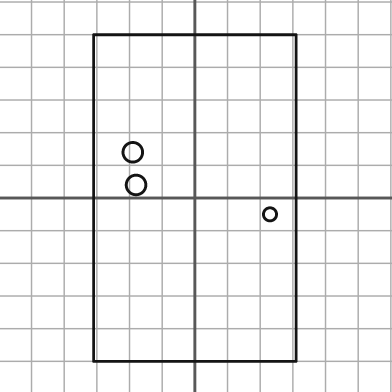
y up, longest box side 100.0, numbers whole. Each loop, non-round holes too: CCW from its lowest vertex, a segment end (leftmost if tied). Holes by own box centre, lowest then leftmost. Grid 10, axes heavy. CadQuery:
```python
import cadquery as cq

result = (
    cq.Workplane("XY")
    .moveTo(-31.0, -50.0)
    .lineTo(31.0, -50.0)
    .lineTo(31.0, 50.0)
    .lineTo(-31.0, 50.0)
    .close()
    .moveTo(23.0, -5.0)
    .circle(2.0)
    .moveTo(-18.0, 4.0)
    .circle(3.0)
    .moveTo(-19.0, 14.0)
    .circle(3.0)
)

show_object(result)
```